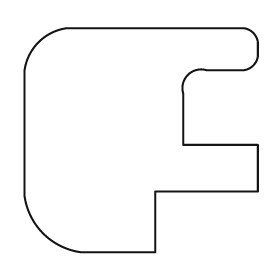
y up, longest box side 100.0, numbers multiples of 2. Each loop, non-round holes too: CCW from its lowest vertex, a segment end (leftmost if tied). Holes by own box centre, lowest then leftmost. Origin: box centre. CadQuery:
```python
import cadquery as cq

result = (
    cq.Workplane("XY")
    .moveTo(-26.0, -48.0)
    .lineTo(6.0, -48.0)
    .lineTo(6.0, -22.0)
    .lineTo(50.0, -22.0)
    .lineTo(50.0, -2.0)
    .lineTo(18.0, -2.0)
    .lineTo(18.0, 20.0)
    .threePointArc((20.0, 28.0), (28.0, 30.0))
    .lineTo(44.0, 30.0)
    .threePointArc((48.0, 32.0), (50.0, 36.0))
    .lineTo(50.0, 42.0)
    .threePointArc((48.0, 46.0), (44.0, 48.0))
    .lineTo(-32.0, 48.0)
    .threePointArc((-44.0, 42.0), (-50.0, 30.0))
    .lineTo(-50.0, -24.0)
    .threePointArc((-42.0, -40.0), (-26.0, -48.0))
    .close()
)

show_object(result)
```